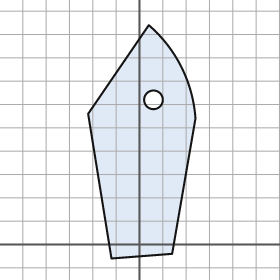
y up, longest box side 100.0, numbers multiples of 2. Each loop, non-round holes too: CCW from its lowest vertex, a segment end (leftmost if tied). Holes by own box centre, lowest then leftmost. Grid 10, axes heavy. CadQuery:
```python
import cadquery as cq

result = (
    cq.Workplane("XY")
    .moveTo(-12.0, -6.0)
    .lineTo(14.0, -4.0)
    .lineTo(24.0, 54.0)
    .threePointArc((18.0, 76.0), (4.0, 94.0))
    .lineTo(-22.0, 56.0)
    .close()
    .moveTo(6.0, 62.0)
    .circle(4.0)
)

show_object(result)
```